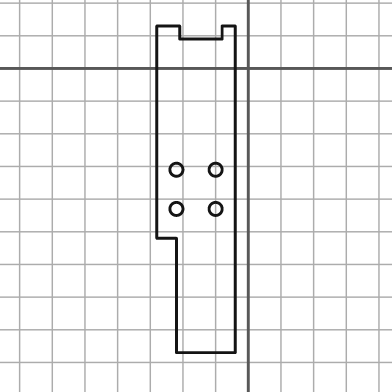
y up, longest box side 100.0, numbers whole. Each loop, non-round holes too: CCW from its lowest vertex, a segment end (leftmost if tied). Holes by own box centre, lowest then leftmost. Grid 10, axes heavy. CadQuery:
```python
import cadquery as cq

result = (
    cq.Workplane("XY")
    .moveTo(-22.0, -87.0)
    .lineTo(-4.0, -87.0)
    .lineTo(-4.0, 13.0)
    .lineTo(-8.0, 13.0)
    .lineTo(-8.0, 9.0)
    .lineTo(-21.0, 9.0)
    .lineTo(-21.0, 13.0)
    .lineTo(-28.0, 13.0)
    .lineTo(-28.0, -52.0)
    .lineTo(-22.0, -52.0)
    .close()
    .moveTo(-22.0, -43.0)
    .circle(2.0)
    .moveTo(-10.0, -43.0)
    .circle(2.0)
    .moveTo(-22.0, -31.0)
    .circle(2.0)
    .moveTo(-10.0, -31.0)
    .circle(2.0)
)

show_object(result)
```